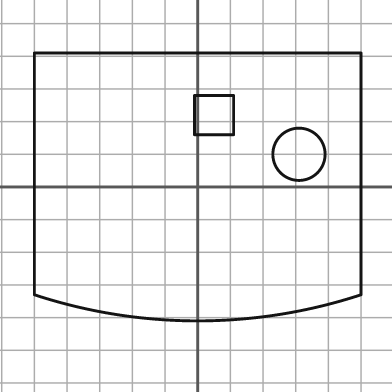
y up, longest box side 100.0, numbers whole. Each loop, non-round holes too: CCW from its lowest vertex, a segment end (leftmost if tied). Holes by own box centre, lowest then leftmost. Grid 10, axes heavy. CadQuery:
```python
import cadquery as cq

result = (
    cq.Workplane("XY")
    .moveTo(-50.0, -33.0)
    .threePointArc((0.0, -41.0), (50.0, -33.0))
    .lineTo(50.0, 41.0)
    .lineTo(-50.0, 41.0)
    .close()
    .moveTo(31.0, 10.0)
    .circle(8.0)
    .moveTo(-1.0, 16.0)
    .lineTo(11.0, 16.0)
    .lineTo(11.0, 28.0)
    .lineTo(-1.0, 28.0)
    .close()
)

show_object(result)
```